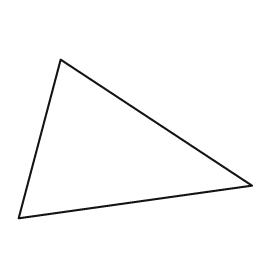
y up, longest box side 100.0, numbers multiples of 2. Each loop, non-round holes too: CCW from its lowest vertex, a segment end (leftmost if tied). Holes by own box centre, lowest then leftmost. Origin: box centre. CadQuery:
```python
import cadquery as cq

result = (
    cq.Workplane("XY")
    .moveTo(-50.0, -34.0)
    .lineTo(50.0, -20.0)
    .lineTo(-32.0, 34.0)
    .close()
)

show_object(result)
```